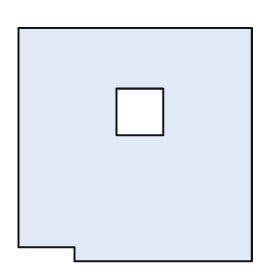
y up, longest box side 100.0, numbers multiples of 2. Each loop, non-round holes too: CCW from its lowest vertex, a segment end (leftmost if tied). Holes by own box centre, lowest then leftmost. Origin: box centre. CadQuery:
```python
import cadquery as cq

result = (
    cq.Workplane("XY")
    .moveTo(-26.0, -50.0)
    .lineTo(50.0, -50.0)
    .lineTo(50.0, 50.0)
    .lineTo(-50.0, 50.0)
    .lineTo(-50.0, -44.0)
    .lineTo(-26.0, -44.0)
    .close()
    .moveTo(-8.0, 4.0)
    .lineTo(12.0, 4.0)
    .lineTo(12.0, 24.0)
    .lineTo(-8.0, 24.0)
    .close()
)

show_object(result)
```